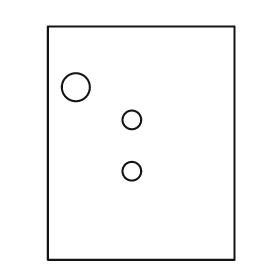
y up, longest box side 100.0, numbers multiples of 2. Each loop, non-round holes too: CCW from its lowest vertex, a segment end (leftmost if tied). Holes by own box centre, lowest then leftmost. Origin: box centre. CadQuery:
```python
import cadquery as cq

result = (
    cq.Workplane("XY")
    .moveTo(-40.0, -50.0)
    .lineTo(40.0, -50.0)
    .lineTo(40.0, 50.0)
    .lineTo(-40.0, 50.0)
    .close()
    .moveTo(-4.0, -12.0)
    .circle(4.0)
    .moveTo(-4.0, 10.0)
    .circle(4.0)
    .moveTo(-28.0, 24.0)
    .circle(6.0)
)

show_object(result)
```